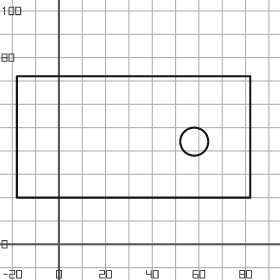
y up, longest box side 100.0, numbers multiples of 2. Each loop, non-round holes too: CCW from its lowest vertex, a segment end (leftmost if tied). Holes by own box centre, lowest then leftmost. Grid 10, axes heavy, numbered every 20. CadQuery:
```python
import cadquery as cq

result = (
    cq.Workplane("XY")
    .moveTo(-18.0, 20.0)
    .lineTo(82.0, 20.0)
    .lineTo(82.0, 72.0)
    .lineTo(-18.0, 72.0)
    .close()
    .moveTo(58.0, 44.0)
    .circle(6.0)
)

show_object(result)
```